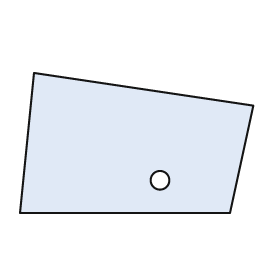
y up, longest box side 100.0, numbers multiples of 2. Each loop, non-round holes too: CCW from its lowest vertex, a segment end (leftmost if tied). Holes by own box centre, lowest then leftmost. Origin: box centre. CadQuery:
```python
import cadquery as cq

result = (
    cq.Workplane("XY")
    .moveTo(-50.0, -30.0)
    .lineTo(40.0, -30.0)
    .lineTo(50.0, 16.0)
    .lineTo(-44.0, 30.0)
    .close()
    .moveTo(10.0, -16.0)
    .circle(4.0)
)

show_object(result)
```